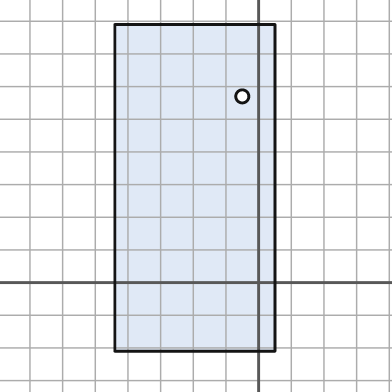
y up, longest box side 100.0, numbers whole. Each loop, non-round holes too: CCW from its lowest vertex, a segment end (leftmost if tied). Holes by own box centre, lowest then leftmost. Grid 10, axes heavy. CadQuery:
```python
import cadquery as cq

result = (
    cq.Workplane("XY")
    .moveTo(-44.0, -21.0)
    .lineTo(5.0, -21.0)
    .lineTo(5.0, 79.0)
    .lineTo(-44.0, 79.0)
    .close()
    .moveTo(-5.0, 57.0)
    .circle(2.0)
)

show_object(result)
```